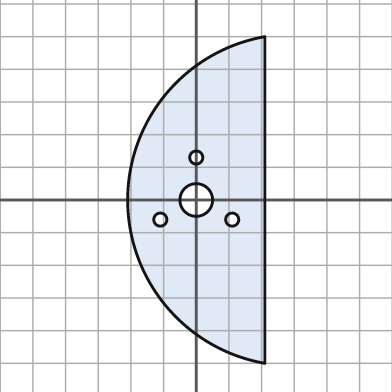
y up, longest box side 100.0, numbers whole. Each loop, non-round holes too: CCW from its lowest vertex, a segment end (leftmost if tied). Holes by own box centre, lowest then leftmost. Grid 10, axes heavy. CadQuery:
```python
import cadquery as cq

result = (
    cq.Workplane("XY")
    .moveTo(21.0, -50.0)
    .lineTo(21.0, 50.0)
    .threePointArc((-21.0, 0.0), (21.0, -50.0))
    .close()
    .moveTo(-11.0, -6.0)
    .circle(2.0)
    .moveTo(11.0, -6.0)
    .circle(2.0)
    .moveTo(0.0, 0.0)
    .circle(5.0)
    .moveTo(0.0, 13.0)
    .circle(2.0)
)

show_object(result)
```